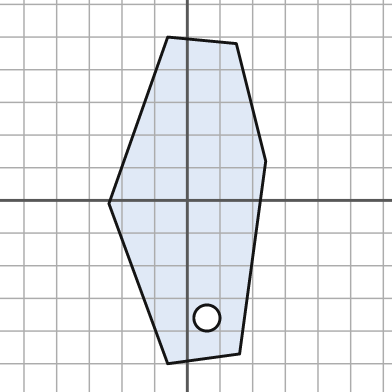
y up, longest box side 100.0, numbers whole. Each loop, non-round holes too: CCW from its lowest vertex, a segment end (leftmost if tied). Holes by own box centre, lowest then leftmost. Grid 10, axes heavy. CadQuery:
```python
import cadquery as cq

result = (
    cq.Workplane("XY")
    .moveTo(-6.0, -50.0)
    .lineTo(16.0, -47.0)
    .lineTo(24.0, 12.0)
    .lineTo(15.0, 48.0)
    .lineTo(-6.0, 50.0)
    .lineTo(-24.0, -1.0)
    .close()
    .moveTo(6.0, -36.0)
    .circle(4.0)
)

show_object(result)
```